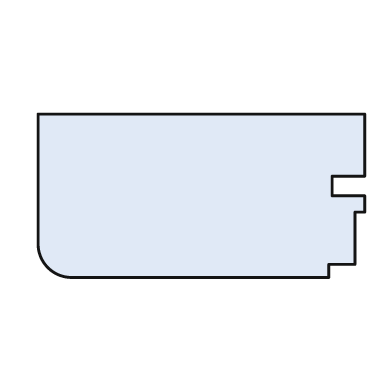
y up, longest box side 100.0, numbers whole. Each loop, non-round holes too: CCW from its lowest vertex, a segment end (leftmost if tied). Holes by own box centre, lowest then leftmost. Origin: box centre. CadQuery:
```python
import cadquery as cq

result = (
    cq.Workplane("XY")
    .moveTo(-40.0, -25.0)
    .lineTo(39.0, -25.0)
    .lineTo(39.0, -21.0)
    .lineTo(47.0, -21.0)
    .lineTo(47.0, -5.0)
    .lineTo(50.0, -5.0)
    .lineTo(50.0, 0.0)
    .lineTo(40.0, 0.0)
    .lineTo(40.0, 6.0)
    .lineTo(50.0, 6.0)
    .lineTo(50.0, 25.0)
    .lineTo(-50.0, 25.0)
    .lineTo(-50.0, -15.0)
    .threePointArc((-47.0, -22.0), (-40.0, -25.0))
    .close()
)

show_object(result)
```